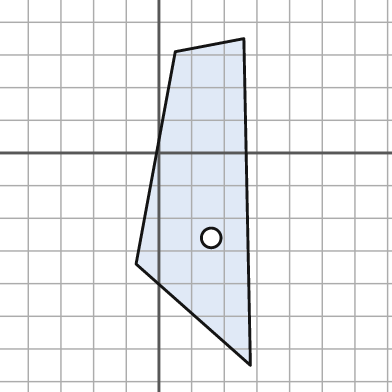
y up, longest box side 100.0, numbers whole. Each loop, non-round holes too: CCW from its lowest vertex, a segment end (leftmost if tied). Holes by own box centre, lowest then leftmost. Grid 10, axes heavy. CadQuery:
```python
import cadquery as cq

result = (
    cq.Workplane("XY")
    .moveTo(28.0, -65.0)
    .lineTo(26.0, 35.0)
    .lineTo(5.0, 31.0)
    .lineTo(-7.0, -34.0)
    .close()
    .moveTo(16.0, -26.0)
    .circle(3.0)
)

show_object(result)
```